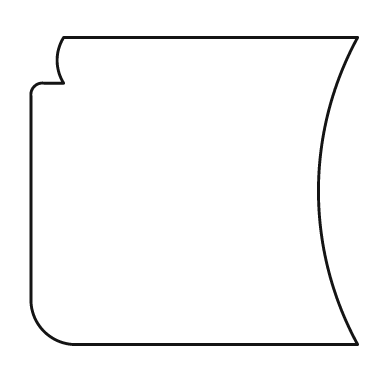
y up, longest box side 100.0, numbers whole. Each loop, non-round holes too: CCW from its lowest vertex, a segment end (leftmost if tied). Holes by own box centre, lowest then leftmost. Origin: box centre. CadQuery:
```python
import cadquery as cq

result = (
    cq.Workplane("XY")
    .moveTo(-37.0, -47.0)
    .lineTo(50.0, -47.0)
    .threePointArc((38.0, 0.0), (50.0, 47.0))
    .lineTo(-40.0, 47.0)
    .threePointArc((-42.0, 40.0), (-40.0, 33.0))
    .lineTo(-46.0, 33.0)
    .threePointArc((-49.0, 32.0), (-50.0, 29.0))
    .lineTo(-50.0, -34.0)
    .threePointArc((-46.0, -43.0), (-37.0, -47.0))
    .close()
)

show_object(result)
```